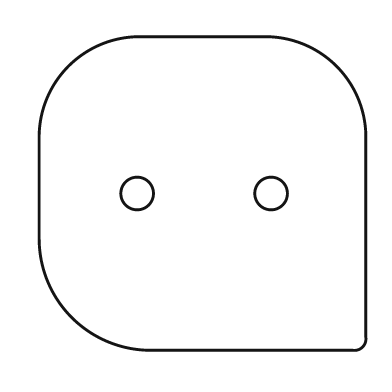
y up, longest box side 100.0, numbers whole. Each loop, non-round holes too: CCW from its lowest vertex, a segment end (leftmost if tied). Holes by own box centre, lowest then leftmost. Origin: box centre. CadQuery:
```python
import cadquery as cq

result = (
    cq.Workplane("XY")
    .moveTo(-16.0, -48.0)
    .lineTo(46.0, -48.0)
    .threePointArc((49.0, -47.0), (50.0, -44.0))
    .lineTo(50.0, 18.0)
    .threePointArc((41.0, 39.0), (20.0, 48.0))
    .lineTo(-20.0, 48.0)
    .threePointArc((-41.0, 39.0), (-50.0, 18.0))
    .lineTo(-50.0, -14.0)
    .threePointArc((-40.0, -38.0), (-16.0, -48.0))
    .close()
    .moveTo(-20.0, 0.0)
    .circle(5.0)
    .moveTo(21.0, 0.0)
    .circle(5.0)
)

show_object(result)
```